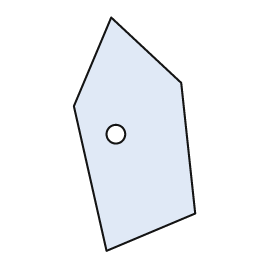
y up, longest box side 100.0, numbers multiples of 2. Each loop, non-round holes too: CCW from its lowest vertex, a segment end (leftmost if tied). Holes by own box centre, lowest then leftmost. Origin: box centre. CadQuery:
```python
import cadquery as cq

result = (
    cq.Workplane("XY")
    .moveTo(-12.0, -50.0)
    .lineTo(26.0, -34.0)
    .lineTo(20.0, 22.0)
    .lineTo(-10.0, 50.0)
    .lineTo(-26.0, 12.0)
    .close()
    .moveTo(-8.0, 0.0)
    .circle(4.0)
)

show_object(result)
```